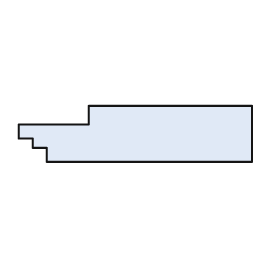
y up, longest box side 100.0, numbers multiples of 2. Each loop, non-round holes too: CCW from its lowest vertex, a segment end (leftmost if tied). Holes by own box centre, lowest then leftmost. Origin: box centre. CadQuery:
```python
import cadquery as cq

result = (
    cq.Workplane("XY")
    .moveTo(-38.0, -12.0)
    .lineTo(50.0, -12.0)
    .lineTo(50.0, 12.0)
    .lineTo(-20.0, 12.0)
    .lineTo(-20.0, 4.0)
    .lineTo(-50.0, 4.0)
    .lineTo(-50.0, -2.0)
    .lineTo(-44.0, -2.0)
    .lineTo(-44.0, -6.0)
    .lineTo(-38.0, -6.0)
    .close()
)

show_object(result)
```